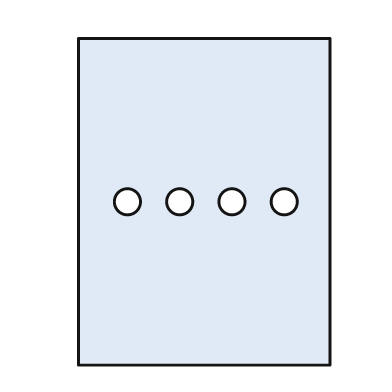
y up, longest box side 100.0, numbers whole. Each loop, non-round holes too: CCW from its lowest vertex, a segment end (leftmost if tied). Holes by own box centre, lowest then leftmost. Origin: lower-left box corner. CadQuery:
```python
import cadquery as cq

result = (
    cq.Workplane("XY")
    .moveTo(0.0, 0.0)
    .lineTo(77.0, 0.0)
    .lineTo(77.0, 100.0)
    .lineTo(0.0, 100.0)
    .close()
    .moveTo(15.0, 50.0)
    .circle(4.0)
    .moveTo(31.0, 50.0)
    .circle(4.0)
    .moveTo(47.0, 50.0)
    .circle(4.0)
    .moveTo(63.0, 50.0)
    .circle(4.0)
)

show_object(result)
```